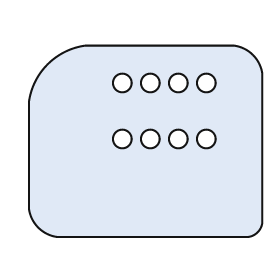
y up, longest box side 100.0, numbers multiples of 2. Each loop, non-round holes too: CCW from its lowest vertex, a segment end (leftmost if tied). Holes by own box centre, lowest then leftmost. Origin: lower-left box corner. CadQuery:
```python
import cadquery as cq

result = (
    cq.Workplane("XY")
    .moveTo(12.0, 0.0)
    .lineTo(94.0, 0.0)
    .threePointArc((98.0, 2.0), (100.0, 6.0))
    .lineTo(100.0, 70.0)
    .threePointArc((96.0, 78.0), (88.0, 82.0))
    .lineTo(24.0, 82.0)
    .threePointArc((8.0, 74.0), (0.0, 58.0))
    .lineTo(0.0, 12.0)
    .threePointArc((4.0, 4.0), (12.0, 0.0))
    .close()
    .moveTo(40.0, 42.0)
    .circle(4.0)
    .moveTo(52.0, 42.0)
    .circle(4.0)
    .moveTo(64.0, 42.0)
    .circle(4.0)
    .moveTo(76.0, 42.0)
    .circle(4.0)
    .moveTo(40.0, 66.0)
    .circle(4.0)
    .moveTo(52.0, 66.0)
    .circle(4.0)
    .moveTo(64.0, 66.0)
    .circle(4.0)
    .moveTo(76.0, 66.0)
    .circle(4.0)
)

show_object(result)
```